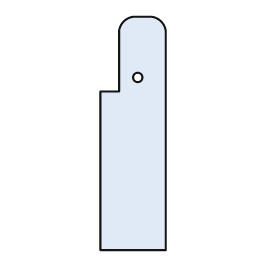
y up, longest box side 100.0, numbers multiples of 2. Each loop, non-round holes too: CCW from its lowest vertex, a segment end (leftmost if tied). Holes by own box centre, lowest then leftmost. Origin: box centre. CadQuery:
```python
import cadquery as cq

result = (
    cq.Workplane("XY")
    .moveTo(-14.0, -50.0)
    .lineTo(14.0, -50.0)
    .lineTo(14.0, 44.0)
    .threePointArc((12.0, 48.0), (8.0, 50.0))
    .lineTo(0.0, 50.0)
    .threePointArc((-4.0, 48.0), (-6.0, 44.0))
    .lineTo(-6.0, 18.0)
    .lineTo(-14.0, 18.0)
    .close()
    .moveTo(2.0, 24.0)
    .circle(2.0)
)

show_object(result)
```